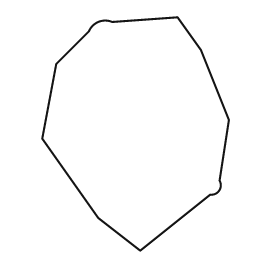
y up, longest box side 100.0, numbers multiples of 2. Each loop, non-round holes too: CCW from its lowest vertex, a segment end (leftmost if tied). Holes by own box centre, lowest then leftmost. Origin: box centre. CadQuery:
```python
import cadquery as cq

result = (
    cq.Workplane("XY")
    .moveTo(2.0, -50.0)
    .lineTo(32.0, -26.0)
    .threePointArc((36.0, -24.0), (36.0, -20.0))
    .lineTo(40.0, 6.0)
    .lineTo(28.0, 36.0)
    .lineTo(18.0, 50.0)
    .lineTo(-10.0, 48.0)
    .threePointArc((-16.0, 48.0), (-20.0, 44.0))
    .lineTo(-34.0, 30.0)
    .lineTo(-40.0, -2.0)
    .lineTo(-16.0, -36.0)
    .close()
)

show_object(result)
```